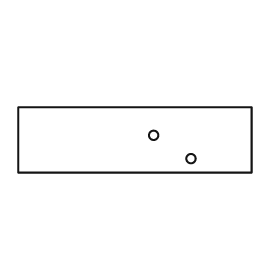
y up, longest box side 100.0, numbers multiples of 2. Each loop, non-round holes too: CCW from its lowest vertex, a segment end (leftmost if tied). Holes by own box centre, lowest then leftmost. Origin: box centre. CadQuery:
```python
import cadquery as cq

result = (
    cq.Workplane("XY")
    .moveTo(-50.0, -14.0)
    .lineTo(50.0, -14.0)
    .lineTo(50.0, 14.0)
    .lineTo(-50.0, 14.0)
    .close()
    .moveTo(24.0, -8.0)
    .circle(2.0)
    .moveTo(8.0, 2.0)
    .circle(2.0)
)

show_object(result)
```